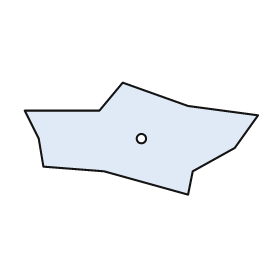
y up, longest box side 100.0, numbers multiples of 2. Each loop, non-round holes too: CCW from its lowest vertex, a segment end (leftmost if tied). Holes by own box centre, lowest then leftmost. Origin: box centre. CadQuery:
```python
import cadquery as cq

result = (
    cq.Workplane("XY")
    .moveTo(20.0, -24.0)
    .lineTo(22.0, -14.0)
    .lineTo(40.0, -4.0)
    .lineTo(50.0, 10.0)
    .lineTo(20.0, 14.0)
    .lineTo(-8.0, 24.0)
    .lineTo(-18.0, 12.0)
    .lineTo(-50.0, 12.0)
    .lineTo(-44.0, 0.0)
    .lineTo(-42.0, -12.0)
    .lineTo(-16.0, -14.0)
    .close()
    .moveTo(0.0, 0.0)
    .circle(2.0)
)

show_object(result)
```